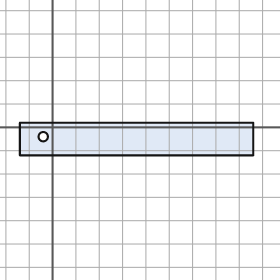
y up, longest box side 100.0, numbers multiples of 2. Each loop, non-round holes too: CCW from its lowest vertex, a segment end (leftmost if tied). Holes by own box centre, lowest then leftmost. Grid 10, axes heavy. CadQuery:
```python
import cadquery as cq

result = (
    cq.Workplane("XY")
    .moveTo(-14.0, -12.0)
    .lineTo(86.0, -12.0)
    .lineTo(86.0, 2.0)
    .lineTo(-14.0, 2.0)
    .close()
    .moveTo(-4.0, -4.0)
    .circle(2.0)
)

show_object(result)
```